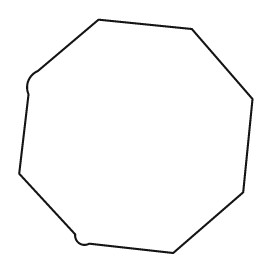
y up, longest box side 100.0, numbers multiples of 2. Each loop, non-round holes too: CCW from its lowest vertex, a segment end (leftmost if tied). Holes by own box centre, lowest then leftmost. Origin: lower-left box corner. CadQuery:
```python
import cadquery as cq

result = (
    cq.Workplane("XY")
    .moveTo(66.0, 0.0)
    .lineTo(96.0, 26.0)
    .lineTo(100.0, 66.0)
    .lineTo(74.0, 96.0)
    .lineTo(34.0, 100.0)
    .lineTo(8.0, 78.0)
    .threePointArc((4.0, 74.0), (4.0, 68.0))
    .lineTo(0.0, 34.0)
    .lineTo(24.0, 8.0)
    .threePointArc((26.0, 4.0), (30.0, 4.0))
    .close()
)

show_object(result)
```